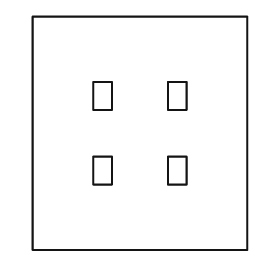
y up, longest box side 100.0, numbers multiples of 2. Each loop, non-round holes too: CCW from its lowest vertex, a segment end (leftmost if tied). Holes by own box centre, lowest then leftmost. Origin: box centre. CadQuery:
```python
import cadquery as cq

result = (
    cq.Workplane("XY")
    .moveTo(-46.0, -50.0)
    .lineTo(46.0, -50.0)
    .lineTo(46.0, 50.0)
    .lineTo(-46.0, 50.0)
    .close()
    .moveTo(-20.0, -22.0)
    .lineTo(-12.0, -22.0)
    .lineTo(-12.0, -10.0)
    .lineTo(-20.0, -10.0)
    .close()
    .moveTo(12.0, -22.0)
    .lineTo(20.0, -22.0)
    .lineTo(20.0, -10.0)
    .lineTo(12.0, -10.0)
    .close()
    .moveTo(-20.0, 10.0)
    .lineTo(-12.0, 10.0)
    .lineTo(-12.0, 22.0)
    .lineTo(-20.0, 22.0)
    .close()
    .moveTo(12.0, 10.0)
    .lineTo(20.0, 10.0)
    .lineTo(20.0, 22.0)
    .lineTo(12.0, 22.0)
    .close()
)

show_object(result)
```